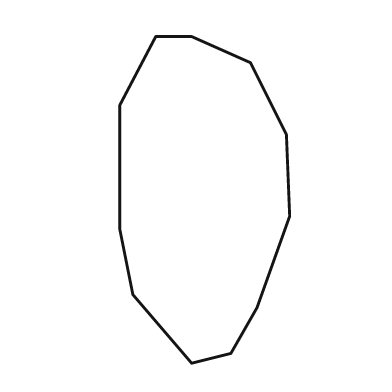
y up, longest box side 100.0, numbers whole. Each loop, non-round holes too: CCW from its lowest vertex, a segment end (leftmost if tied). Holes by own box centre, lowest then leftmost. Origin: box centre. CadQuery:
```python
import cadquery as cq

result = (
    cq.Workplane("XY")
    .moveTo(-4.0, -50.0)
    .lineTo(8.0, -47.0)
    .lineTo(16.0, -33.0)
    .lineTo(26.0, -5.0)
    .lineTo(25.0, 20.0)
    .lineTo(14.0, 42.0)
    .lineTo(-4.0, 50.0)
    .lineTo(-15.0, 50.0)
    .lineTo(-26.0, 29.0)
    .lineTo(-26.0, -9.0)
    .lineTo(-22.0, -29.0)
    .close()
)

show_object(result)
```